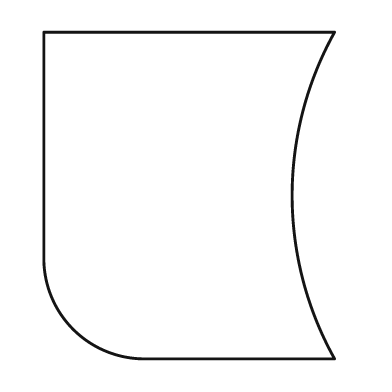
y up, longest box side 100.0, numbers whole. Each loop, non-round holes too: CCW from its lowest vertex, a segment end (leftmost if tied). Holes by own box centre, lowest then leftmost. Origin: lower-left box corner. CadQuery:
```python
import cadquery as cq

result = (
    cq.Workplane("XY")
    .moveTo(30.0, 0.0)
    .lineTo(89.0, 0.0)
    .threePointArc((76.0, 50.0), (89.0, 100.0))
    .lineTo(0.0, 100.0)
    .lineTo(0.0, 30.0)
    .threePointArc((9.0, 9.0), (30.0, 0.0))
    .close()
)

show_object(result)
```